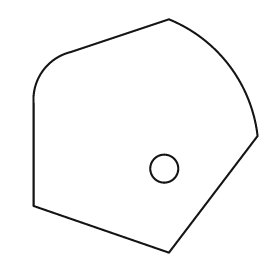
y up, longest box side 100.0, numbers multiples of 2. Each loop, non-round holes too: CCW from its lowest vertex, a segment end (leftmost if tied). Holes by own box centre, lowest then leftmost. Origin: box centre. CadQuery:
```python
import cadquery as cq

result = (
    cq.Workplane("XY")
    .moveTo(10.0, -50.0)
    .lineTo(48.0, 0.0)
    .threePointArc((36.0, 30.0), (10.0, 50.0))
    .lineTo(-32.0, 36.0)
    .threePointArc((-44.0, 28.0), (-48.0, 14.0))
    .lineTo(-48.0, -30.0)
    .close()
    .moveTo(8.0, -14.0)
    .circle(6.0)
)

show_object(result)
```